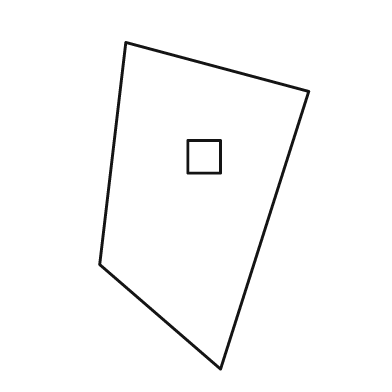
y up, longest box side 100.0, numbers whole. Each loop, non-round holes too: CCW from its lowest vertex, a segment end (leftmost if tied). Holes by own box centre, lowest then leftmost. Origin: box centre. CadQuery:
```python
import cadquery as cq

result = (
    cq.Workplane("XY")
    .moveTo(5.0, -50.0)
    .lineTo(32.0, 35.0)
    .lineTo(-24.0, 50.0)
    .lineTo(-32.0, -18.0)
    .close()
    .moveTo(-5.0, 10.0)
    .lineTo(5.0, 10.0)
    .lineTo(5.0, 20.0)
    .lineTo(-5.0, 20.0)
    .close()
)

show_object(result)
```